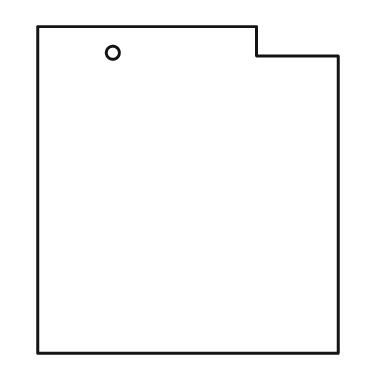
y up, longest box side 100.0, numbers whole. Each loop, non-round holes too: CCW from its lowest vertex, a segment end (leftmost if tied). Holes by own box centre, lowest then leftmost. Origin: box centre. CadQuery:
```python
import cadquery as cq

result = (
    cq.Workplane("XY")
    .moveTo(-46.0, -50.0)
    .lineTo(46.0, -50.0)
    .lineTo(46.0, 41.0)
    .lineTo(21.0, 41.0)
    .lineTo(21.0, 50.0)
    .lineTo(-46.0, 50.0)
    .close()
    .moveTo(-23.0, 42.0)
    .circle(2.0)
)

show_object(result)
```